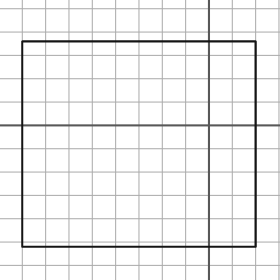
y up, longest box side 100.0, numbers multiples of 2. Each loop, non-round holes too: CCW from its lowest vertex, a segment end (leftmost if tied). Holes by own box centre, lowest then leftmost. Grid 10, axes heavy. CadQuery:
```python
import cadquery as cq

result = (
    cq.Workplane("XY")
    .moveTo(-80.0, -52.0)
    .lineTo(20.0, -52.0)
    .lineTo(20.0, 36.0)
    .lineTo(-80.0, 36.0)
    .close()
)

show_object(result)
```